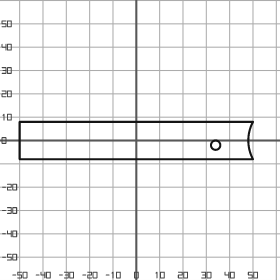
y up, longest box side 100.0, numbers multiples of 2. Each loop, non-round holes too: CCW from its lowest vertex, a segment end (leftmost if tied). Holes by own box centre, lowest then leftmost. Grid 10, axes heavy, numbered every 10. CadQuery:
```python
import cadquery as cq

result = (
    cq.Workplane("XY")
    .moveTo(-50.0, -8.0)
    .lineTo(50.0, -8.0)
    .threePointArc((48.0, 0.0), (50.0, 8.0))
    .lineTo(-50.0, 8.0)
    .close()
    .moveTo(34.0, -2.0)
    .circle(2.0)
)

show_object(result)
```